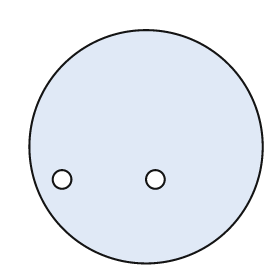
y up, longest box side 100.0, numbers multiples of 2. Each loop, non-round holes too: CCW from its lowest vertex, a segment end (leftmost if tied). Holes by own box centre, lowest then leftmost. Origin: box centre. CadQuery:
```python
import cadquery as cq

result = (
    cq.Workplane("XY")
    .moveTo(0.0, 0.0)
    .circle(50.0)
    .moveTo(-36.0, -14.0)
    .circle(4.0)
    .moveTo(4.0, -14.0)
    .circle(4.0)
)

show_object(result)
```